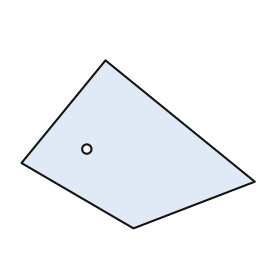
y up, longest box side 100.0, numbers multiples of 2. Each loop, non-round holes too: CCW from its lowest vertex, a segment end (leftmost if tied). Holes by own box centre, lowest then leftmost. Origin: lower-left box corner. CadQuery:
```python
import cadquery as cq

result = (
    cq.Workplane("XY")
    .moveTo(48.0, 0.0)
    .lineTo(100.0, 20.0)
    .lineTo(36.0, 72.0)
    .lineTo(0.0, 28.0)
    .close()
    .moveTo(28.0, 34.0)
    .circle(2.0)
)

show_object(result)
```